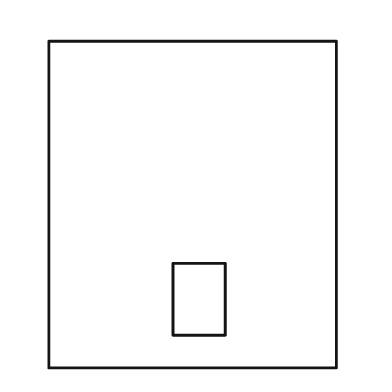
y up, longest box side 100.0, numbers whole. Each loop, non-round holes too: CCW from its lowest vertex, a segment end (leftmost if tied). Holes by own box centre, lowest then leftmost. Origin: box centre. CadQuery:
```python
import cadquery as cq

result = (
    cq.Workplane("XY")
    .moveTo(-44.0, -50.0)
    .lineTo(44.0, -50.0)
    .lineTo(44.0, 50.0)
    .lineTo(-44.0, 50.0)
    .close()
    .moveTo(-6.0, -40.0)
    .lineTo(10.0, -40.0)
    .lineTo(10.0, -18.0)
    .lineTo(-6.0, -18.0)
    .close()
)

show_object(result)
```